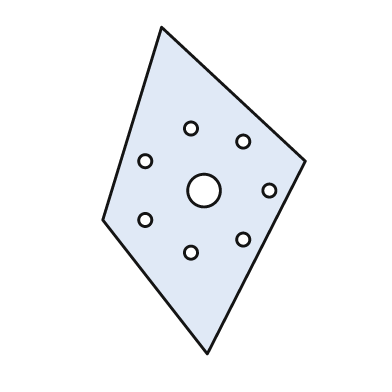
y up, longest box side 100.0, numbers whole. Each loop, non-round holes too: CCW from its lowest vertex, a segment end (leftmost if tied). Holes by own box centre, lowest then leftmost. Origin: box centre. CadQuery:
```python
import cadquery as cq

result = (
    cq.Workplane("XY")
    .moveTo(1.0, -50.0)
    .lineTo(31.0, 9.0)
    .lineTo(-13.0, 50.0)
    .lineTo(-31.0, -9.0)
    .close()
    .moveTo(-4.0, -19.0)
    .circle(2.0)
    .moveTo(12.0, -15.0)
    .circle(2.0)
    .moveTo(-18.0, -9.0)
    .circle(2.0)
    .moveTo(0.0, 0.0)
    .circle(5.0)
    .moveTo(20.0, 0.0)
    .circle(2.0)
    .moveTo(-18.0, 9.0)
    .circle(2.0)
    .moveTo(12.0, 15.0)
    .circle(2.0)
    .moveTo(-4.0, 19.0)
    .circle(2.0)
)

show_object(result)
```